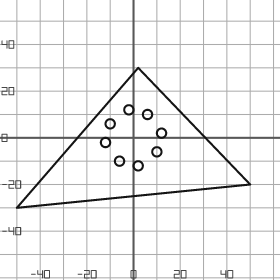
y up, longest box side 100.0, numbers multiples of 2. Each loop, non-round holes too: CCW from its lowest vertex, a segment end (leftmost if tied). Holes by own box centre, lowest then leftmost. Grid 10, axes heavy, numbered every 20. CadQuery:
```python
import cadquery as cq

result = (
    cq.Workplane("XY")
    .moveTo(-50.0, -30.0)
    .lineTo(50.0, -20.0)
    .lineTo(2.0, 30.0)
    .close()
    .moveTo(2.0, -12.0)
    .circle(2.0)
    .moveTo(-6.0, -10.0)
    .circle(2.0)
    .moveTo(10.0, -6.0)
    .circle(2.0)
    .moveTo(-12.0, -2.0)
    .circle(2.0)
    .moveTo(12.0, 2.0)
    .circle(2.0)
    .moveTo(-10.0, 6.0)
    .circle(2.0)
    .moveTo(6.0, 10.0)
    .circle(2.0)
    .moveTo(-2.0, 12.0)
    .circle(2.0)
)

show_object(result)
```